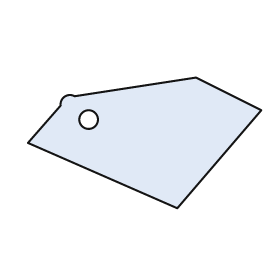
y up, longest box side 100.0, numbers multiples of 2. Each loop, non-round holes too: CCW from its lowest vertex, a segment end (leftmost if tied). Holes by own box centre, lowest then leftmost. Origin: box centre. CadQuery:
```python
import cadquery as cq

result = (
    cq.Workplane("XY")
    .moveTo(14.0, -28.0)
    .lineTo(50.0, 14.0)
    .lineTo(22.0, 28.0)
    .lineTo(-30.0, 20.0)
    .threePointArc((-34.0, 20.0), (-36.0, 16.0))
    .lineTo(-50.0, 0.0)
    .close()
    .moveTo(-24.0, 10.0)
    .circle(4.0)
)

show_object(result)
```